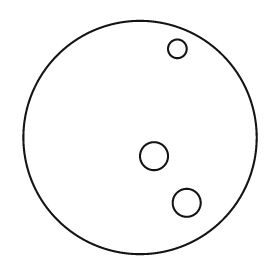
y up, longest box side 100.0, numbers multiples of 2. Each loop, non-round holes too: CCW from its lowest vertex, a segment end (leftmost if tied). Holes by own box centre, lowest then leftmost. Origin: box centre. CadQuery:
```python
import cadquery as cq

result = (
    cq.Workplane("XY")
    .moveTo(0.0, 0.0)
    .circle(50.0)
    .moveTo(20.0, -28.0)
    .circle(6.0)
    .moveTo(6.0, -8.0)
    .circle(6.0)
    .moveTo(16.0, 38.0)
    .circle(4.0)
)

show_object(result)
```